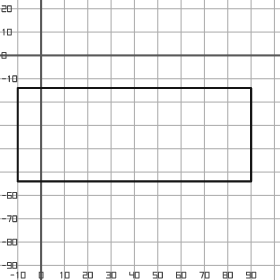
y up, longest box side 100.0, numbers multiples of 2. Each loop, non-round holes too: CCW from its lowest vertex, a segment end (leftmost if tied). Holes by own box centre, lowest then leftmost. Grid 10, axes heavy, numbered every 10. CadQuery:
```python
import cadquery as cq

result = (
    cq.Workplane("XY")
    .moveTo(-10.0, -54.0)
    .lineTo(90.0, -54.0)
    .lineTo(90.0, -14.0)
    .lineTo(-10.0, -14.0)
    .close()
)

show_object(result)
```